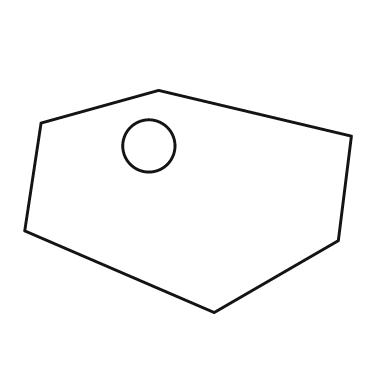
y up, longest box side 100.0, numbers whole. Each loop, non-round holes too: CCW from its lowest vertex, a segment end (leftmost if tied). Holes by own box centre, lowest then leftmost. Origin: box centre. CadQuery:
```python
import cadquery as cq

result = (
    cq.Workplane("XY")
    .moveTo(8.0, -34.0)
    .lineTo(46.0, -12.0)
    .lineTo(50.0, 20.0)
    .lineTo(-9.0, 34.0)
    .lineTo(-45.0, 24.0)
    .lineTo(-50.0, -9.0)
    .close()
    .moveTo(-12.0, 17.0)
    .circle(8.0)
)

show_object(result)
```